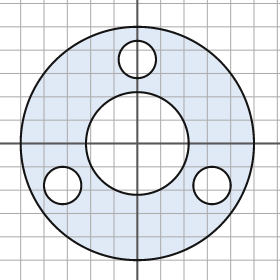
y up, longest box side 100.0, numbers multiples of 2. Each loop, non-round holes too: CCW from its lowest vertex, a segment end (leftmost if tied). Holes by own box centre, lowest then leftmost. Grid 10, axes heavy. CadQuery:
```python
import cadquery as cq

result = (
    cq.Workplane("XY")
    .moveTo(0.0, 0.0)
    .circle(50.0)
    .moveTo(-32.0, -18.0)
    .circle(8.0)
    .moveTo(32.0, -18.0)
    .circle(8.0)
    .moveTo(0.0, 0.0)
    .circle(22.0)
    .moveTo(0.0, 36.0)
    .circle(8.0)
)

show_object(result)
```